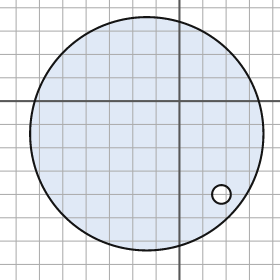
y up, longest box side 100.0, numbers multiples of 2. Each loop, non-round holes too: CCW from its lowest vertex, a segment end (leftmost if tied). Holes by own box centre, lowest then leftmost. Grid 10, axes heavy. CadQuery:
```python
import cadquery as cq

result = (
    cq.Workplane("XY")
    .moveTo(-14.0, -14.0)
    .circle(50.0)
    .moveTo(18.0, -40.0)
    .circle(4.0)
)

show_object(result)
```